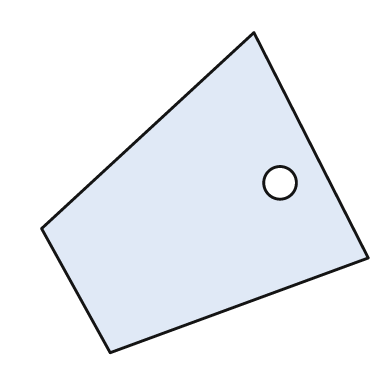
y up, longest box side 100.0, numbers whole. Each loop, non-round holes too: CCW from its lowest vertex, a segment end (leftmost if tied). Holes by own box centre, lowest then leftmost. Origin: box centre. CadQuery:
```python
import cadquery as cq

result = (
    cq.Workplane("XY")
    .moveTo(-29.0, -49.0)
    .lineTo(50.0, -20.0)
    .lineTo(15.0, 49.0)
    .lineTo(-50.0, -11.0)
    .close()
    .moveTo(23.0, 3.0)
    .circle(5.0)
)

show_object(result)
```